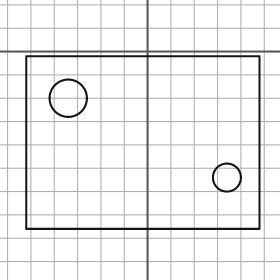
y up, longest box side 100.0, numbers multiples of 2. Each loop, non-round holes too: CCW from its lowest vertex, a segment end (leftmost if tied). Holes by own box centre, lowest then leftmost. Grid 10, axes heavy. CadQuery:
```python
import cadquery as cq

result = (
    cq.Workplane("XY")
    .moveTo(-52.0, -76.0)
    .lineTo(48.0, -76.0)
    .lineTo(48.0, -2.0)
    .lineTo(-52.0, -2.0)
    .close()
    .moveTo(34.0, -54.0)
    .circle(6.0)
    .moveTo(-34.0, -20.0)
    .circle(8.0)
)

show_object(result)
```